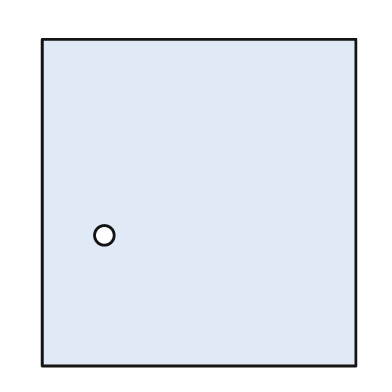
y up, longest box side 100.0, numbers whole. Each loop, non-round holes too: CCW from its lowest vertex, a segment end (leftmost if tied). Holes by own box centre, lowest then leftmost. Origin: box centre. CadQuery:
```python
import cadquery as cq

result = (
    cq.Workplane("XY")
    .moveTo(-48.0, -50.0)
    .lineTo(48.0, -50.0)
    .lineTo(48.0, 50.0)
    .lineTo(-48.0, 50.0)
    .close()
    .moveTo(-29.0, -10.0)
    .circle(3.0)
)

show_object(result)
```